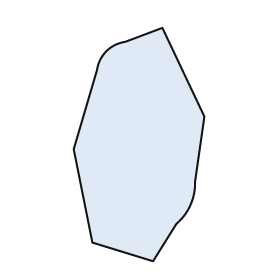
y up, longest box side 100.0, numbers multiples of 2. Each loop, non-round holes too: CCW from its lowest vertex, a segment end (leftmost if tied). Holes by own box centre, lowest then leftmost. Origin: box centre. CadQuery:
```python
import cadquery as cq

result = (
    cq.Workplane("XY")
    .moveTo(6.0, -50.0)
    .lineTo(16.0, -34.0)
    .threePointArc((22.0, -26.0), (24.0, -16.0))
    .lineTo(28.0, 12.0)
    .lineTo(10.0, 50.0)
    .lineTo(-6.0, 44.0)
    .threePointArc((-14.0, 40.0), (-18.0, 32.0))
    .lineTo(-28.0, -2.0)
    .lineTo(-20.0, -42.0)
    .close()
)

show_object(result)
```